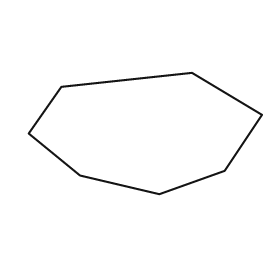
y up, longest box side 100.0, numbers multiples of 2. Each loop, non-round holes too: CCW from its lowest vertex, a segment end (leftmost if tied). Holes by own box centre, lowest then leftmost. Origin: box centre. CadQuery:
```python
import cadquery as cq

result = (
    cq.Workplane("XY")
    .moveTo(6.0, -26.0)
    .lineTo(34.0, -16.0)
    .lineTo(50.0, 8.0)
    .lineTo(20.0, 26.0)
    .lineTo(-36.0, 20.0)
    .lineTo(-50.0, 0.0)
    .lineTo(-28.0, -18.0)
    .close()
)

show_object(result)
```